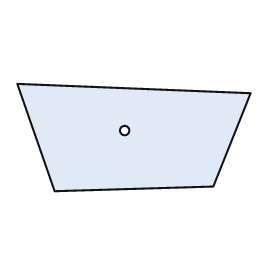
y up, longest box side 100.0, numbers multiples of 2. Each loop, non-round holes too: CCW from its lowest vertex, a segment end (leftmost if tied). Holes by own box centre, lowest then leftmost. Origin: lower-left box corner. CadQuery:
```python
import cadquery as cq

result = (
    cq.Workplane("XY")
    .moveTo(16.0, 0.0)
    .lineTo(84.0, 2.0)
    .lineTo(100.0, 42.0)
    .lineTo(0.0, 46.0)
    .close()
    .moveTo(46.0, 26.0)
    .circle(2.0)
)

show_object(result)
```